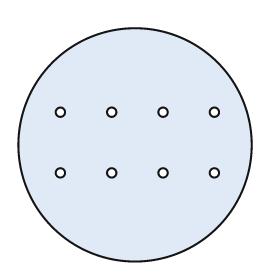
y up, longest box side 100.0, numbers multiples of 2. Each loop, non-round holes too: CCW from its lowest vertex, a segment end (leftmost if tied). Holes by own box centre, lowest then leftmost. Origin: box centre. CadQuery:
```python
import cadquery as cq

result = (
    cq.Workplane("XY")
    .moveTo(0.0, 0.0)
    .circle(50.0)
    .moveTo(-32.0, -12.0)
    .circle(2.0)
    .moveTo(-10.0, -12.0)
    .circle(2.0)
    .moveTo(12.0, -12.0)
    .circle(2.0)
    .moveTo(34.0, -12.0)
    .circle(2.0)
    .moveTo(-32.0, 14.0)
    .circle(2.0)
    .moveTo(-10.0, 14.0)
    .circle(2.0)
    .moveTo(12.0, 14.0)
    .circle(2.0)
    .moveTo(34.0, 14.0)
    .circle(2.0)
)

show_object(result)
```